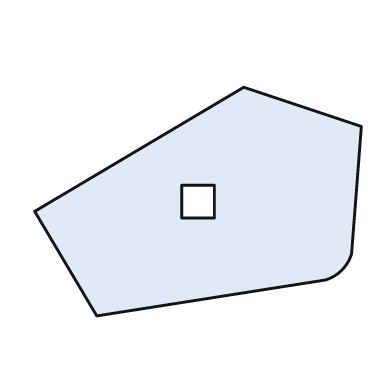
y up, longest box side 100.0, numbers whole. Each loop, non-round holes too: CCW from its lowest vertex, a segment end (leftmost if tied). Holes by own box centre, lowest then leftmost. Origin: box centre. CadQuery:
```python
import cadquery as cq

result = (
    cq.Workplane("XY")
    .moveTo(-31.0, -35.0)
    .lineTo(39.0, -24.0)
    .threePointArc((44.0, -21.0), (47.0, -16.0))
    .lineTo(50.0, 23.0)
    .lineTo(14.0, 35.0)
    .lineTo(-50.0, -3.0)
    .close()
    .moveTo(-5.0, -5.0)
    .lineTo(5.0, -5.0)
    .lineTo(5.0, 5.0)
    .lineTo(-5.0, 5.0)
    .close()
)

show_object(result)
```